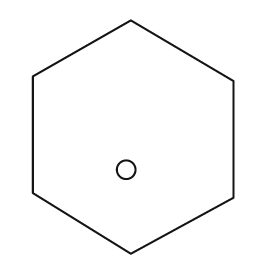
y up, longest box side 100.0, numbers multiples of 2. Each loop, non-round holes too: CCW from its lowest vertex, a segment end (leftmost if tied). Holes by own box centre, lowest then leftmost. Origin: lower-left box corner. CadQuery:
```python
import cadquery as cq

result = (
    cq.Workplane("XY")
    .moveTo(42.0, 0.0)
    .lineTo(86.0, 24.0)
    .lineTo(86.0, 74.0)
    .lineTo(42.0, 100.0)
    .lineTo(0.0, 76.0)
    .lineTo(0.0, 26.0)
    .close()
    .moveTo(40.0, 36.0)
    .circle(4.0)
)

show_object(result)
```